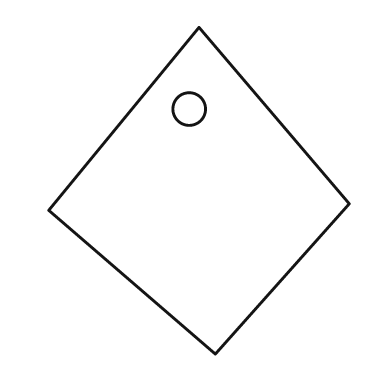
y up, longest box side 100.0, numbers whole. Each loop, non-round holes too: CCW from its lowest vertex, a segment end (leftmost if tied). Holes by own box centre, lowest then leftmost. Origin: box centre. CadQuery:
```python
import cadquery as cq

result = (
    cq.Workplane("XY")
    .moveTo(5.0, -50.0)
    .lineTo(46.0, -4.0)
    .lineTo(0.0, 50.0)
    .lineTo(-46.0, -6.0)
    .close()
    .moveTo(-3.0, 25.0)
    .circle(5.0)
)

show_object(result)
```